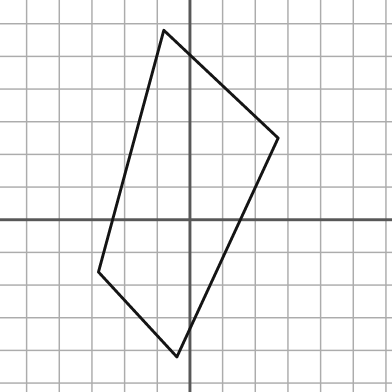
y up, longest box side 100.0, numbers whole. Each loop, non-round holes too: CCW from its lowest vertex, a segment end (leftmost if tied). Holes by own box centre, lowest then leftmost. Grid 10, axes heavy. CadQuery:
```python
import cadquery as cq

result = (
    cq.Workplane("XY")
    .moveTo(-4.0, -42.0)
    .lineTo(27.0, 25.0)
    .lineTo(-8.0, 58.0)
    .lineTo(-28.0, -16.0)
    .close()
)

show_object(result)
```